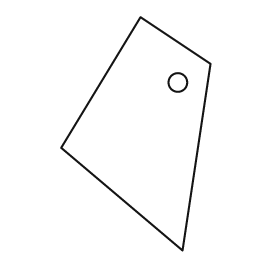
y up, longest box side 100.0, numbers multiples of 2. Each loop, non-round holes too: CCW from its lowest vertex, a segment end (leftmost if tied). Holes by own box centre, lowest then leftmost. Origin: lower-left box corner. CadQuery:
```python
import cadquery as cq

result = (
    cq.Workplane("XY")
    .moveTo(52.0, 0.0)
    .lineTo(64.0, 80.0)
    .lineTo(34.0, 100.0)
    .lineTo(0.0, 44.0)
    .close()
    .moveTo(50.0, 72.0)
    .circle(4.0)
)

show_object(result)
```